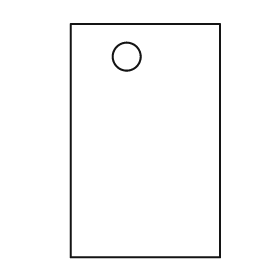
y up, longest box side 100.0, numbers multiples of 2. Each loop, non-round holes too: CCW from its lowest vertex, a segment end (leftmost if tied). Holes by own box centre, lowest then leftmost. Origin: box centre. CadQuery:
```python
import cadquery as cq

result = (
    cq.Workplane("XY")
    .moveTo(-32.0, -50.0)
    .lineTo(32.0, -50.0)
    .lineTo(32.0, 50.0)
    .lineTo(-32.0, 50.0)
    .close()
    .moveTo(-8.0, 36.0)
    .circle(6.0)
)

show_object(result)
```